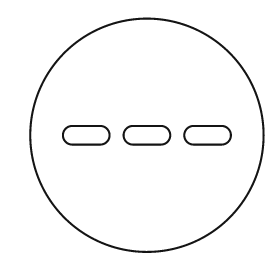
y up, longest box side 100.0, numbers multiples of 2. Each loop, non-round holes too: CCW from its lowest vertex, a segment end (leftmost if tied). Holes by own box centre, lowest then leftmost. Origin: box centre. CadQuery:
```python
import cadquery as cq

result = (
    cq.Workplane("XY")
    .moveTo(0.0, 0.0)
    .circle(50.0)
    .moveTo(-32.0, -4.0)
    .lineTo(-20.0, -4.0)
    .threePointArc((-16.0, 0.0), (-20.0, 4.0))
    .lineTo(-32.0, 4.0)
    .threePointArc((-36.0, 0.0), (-32.0, -4.0))
    .close()
    .moveTo(-6.0, -4.0)
    .lineTo(6.0, -4.0)
    .threePointArc((10.0, 0.0), (6.0, 4.0))
    .lineTo(-6.0, 4.0)
    .threePointArc((-10.0, 0.0), (-6.0, -4.0))
    .close()
    .moveTo(20.0, -4.0)
    .lineTo(32.0, -4.0)
    .threePointArc((36.0, 0.0), (32.0, 4.0))
    .lineTo(20.0, 4.0)
    .threePointArc((16.0, 0.0), (20.0, -4.0))
    .close()
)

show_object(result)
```